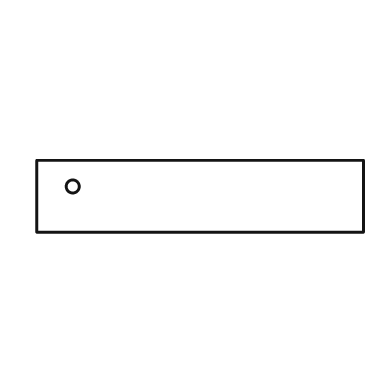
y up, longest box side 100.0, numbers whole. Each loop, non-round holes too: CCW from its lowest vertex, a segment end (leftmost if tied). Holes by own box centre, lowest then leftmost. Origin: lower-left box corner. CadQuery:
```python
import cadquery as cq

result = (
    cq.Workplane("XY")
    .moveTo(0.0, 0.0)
    .lineTo(100.0, 0.0)
    .lineTo(100.0, 22.0)
    .lineTo(0.0, 22.0)
    .close()
    .moveTo(11.0, 14.0)
    .circle(2.0)
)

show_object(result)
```